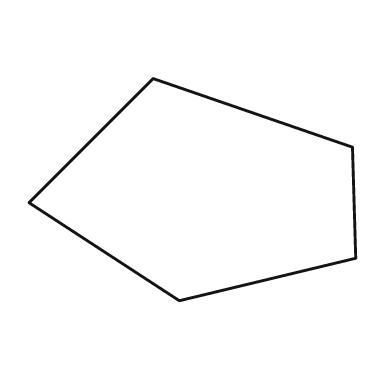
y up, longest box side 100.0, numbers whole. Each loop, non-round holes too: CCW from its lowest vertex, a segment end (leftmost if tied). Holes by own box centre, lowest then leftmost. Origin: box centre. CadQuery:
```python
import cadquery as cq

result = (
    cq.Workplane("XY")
    .moveTo(-4.0, -34.0)
    .lineTo(50.0, -21.0)
    .lineTo(49.0, 13.0)
    .lineTo(-12.0, 34.0)
    .lineTo(-50.0, -4.0)
    .close()
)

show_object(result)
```